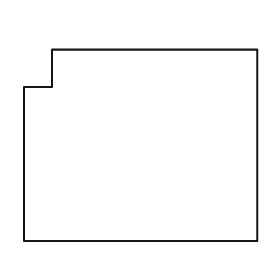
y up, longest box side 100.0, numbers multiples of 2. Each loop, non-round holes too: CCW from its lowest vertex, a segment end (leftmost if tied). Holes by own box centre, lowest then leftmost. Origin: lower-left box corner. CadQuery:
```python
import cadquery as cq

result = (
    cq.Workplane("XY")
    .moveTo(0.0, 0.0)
    .lineTo(100.0, 0.0)
    .lineTo(100.0, 82.0)
    .lineTo(12.0, 82.0)
    .lineTo(12.0, 66.0)
    .lineTo(0.0, 66.0)
    .close()
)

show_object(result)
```